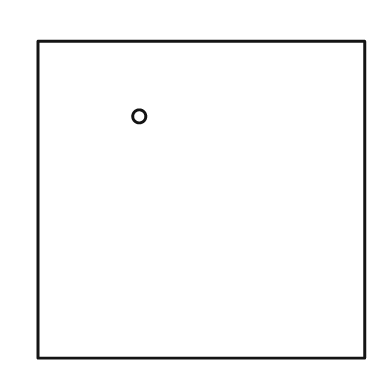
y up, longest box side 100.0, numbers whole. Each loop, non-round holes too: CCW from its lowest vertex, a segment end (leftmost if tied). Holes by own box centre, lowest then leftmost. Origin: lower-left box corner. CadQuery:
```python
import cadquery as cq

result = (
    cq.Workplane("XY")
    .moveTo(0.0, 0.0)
    .lineTo(100.0, 0.0)
    .lineTo(100.0, 97.0)
    .lineTo(0.0, 97.0)
    .close()
    .moveTo(31.0, 74.0)
    .circle(2.0)
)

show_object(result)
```